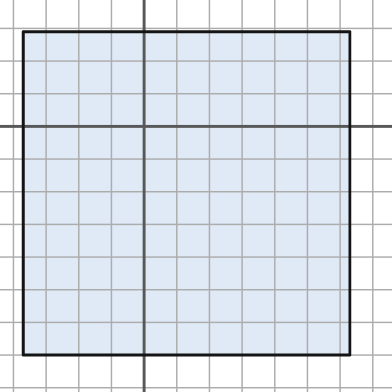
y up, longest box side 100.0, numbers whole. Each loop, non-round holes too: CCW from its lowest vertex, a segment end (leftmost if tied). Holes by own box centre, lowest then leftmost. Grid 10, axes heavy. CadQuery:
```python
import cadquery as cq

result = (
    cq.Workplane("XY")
    .moveTo(-37.0, -70.0)
    .lineTo(63.0, -70.0)
    .lineTo(63.0, 29.0)
    .lineTo(-37.0, 29.0)
    .close()
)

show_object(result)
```